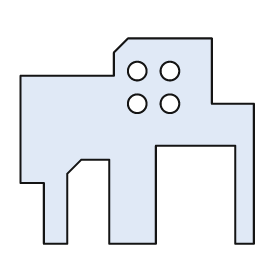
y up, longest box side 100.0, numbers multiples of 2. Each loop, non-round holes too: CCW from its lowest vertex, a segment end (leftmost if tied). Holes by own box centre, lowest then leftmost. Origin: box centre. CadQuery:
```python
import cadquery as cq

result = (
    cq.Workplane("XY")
    .moveTo(-40.0, -44.0)
    .lineTo(-30.0, -44.0)
    .lineTo(-30.0, -14.0)
    .lineTo(-24.0, -8.0)
    .lineTo(-12.0, -8.0)
    .lineTo(-12.0, -44.0)
    .lineTo(8.0, -44.0)
    .lineTo(8.0, -2.0)
    .lineTo(42.0, -2.0)
    .lineTo(42.0, -44.0)
    .lineTo(50.0, -44.0)
    .lineTo(50.0, 16.0)
    .lineTo(32.0, 16.0)
    .lineTo(32.0, 44.0)
    .lineTo(-4.0, 44.0)
    .lineTo(-10.0, 38.0)
    .lineTo(-10.0, 28.0)
    .lineTo(-50.0, 28.0)
    .lineTo(-50.0, -18.0)
    .lineTo(-40.0, -18.0)
    .close()
    .moveTo(0.0, 16.0)
    .circle(4.0)
    .moveTo(14.0, 16.0)
    .circle(4.0)
    .moveTo(0.0, 30.0)
    .circle(4.0)
    .moveTo(14.0, 30.0)
    .circle(4.0)
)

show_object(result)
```